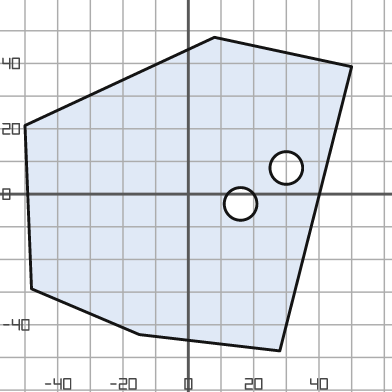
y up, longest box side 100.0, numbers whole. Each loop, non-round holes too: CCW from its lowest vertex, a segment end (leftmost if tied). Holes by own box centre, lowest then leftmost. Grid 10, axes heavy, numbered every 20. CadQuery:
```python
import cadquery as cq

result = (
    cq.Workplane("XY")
    .moveTo(28.0, -48.0)
    .lineTo(50.0, 39.0)
    .lineTo(8.0, 48.0)
    .lineTo(-50.0, 21.0)
    .lineTo(-48.0, -29.0)
    .lineTo(-15.0, -43.0)
    .close()
    .moveTo(16.0, -3.0)
    .circle(5.0)
    .moveTo(30.0, 8.0)
    .circle(5.0)
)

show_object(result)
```